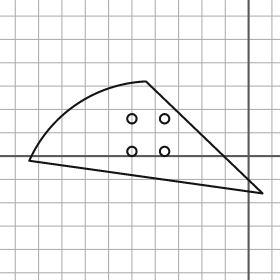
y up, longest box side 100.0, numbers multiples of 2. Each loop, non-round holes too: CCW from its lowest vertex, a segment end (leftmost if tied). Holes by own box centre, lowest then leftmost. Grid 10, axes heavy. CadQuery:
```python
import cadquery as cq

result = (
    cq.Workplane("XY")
    .moveTo(6.0, -16.0)
    .lineTo(-44.0, 32.0)
    .threePointArc((-74.0, 22.0), (-94.0, -2.0))
    .close()
    .moveTo(-50.0, 2.0)
    .circle(2.0)
    .moveTo(-36.0, 2.0)
    .circle(2.0)
    .moveTo(-50.0, 16.0)
    .circle(2.0)
    .moveTo(-36.0, 16.0)
    .circle(2.0)
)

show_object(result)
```